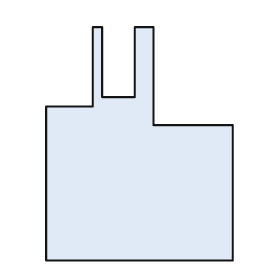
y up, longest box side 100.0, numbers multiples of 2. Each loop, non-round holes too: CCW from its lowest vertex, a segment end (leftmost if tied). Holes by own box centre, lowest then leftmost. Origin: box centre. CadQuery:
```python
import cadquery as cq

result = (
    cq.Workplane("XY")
    .moveTo(-40.0, -50.0)
    .lineTo(40.0, -50.0)
    .lineTo(40.0, 8.0)
    .lineTo(6.0, 8.0)
    .lineTo(6.0, 50.0)
    .lineTo(-2.0, 50.0)
    .lineTo(-2.0, 20.0)
    .lineTo(-16.0, 20.0)
    .lineTo(-16.0, 50.0)
    .lineTo(-20.0, 50.0)
    .lineTo(-20.0, 16.0)
    .lineTo(-40.0, 16.0)
    .close()
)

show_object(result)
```